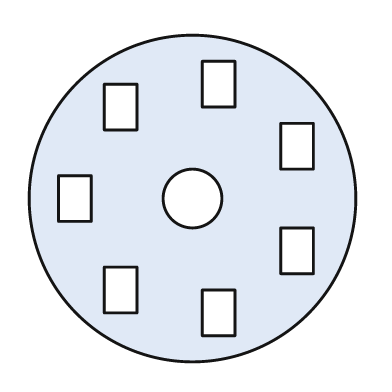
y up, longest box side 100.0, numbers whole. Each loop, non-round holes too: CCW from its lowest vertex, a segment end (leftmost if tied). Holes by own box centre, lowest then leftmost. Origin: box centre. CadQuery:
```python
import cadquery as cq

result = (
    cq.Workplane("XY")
    .moveTo(0.0, 0.0)
    .circle(50.0)
    .moveTo(3.0, -42.0)
    .lineTo(13.0, -42.0)
    .lineTo(13.0, -28.0)
    .lineTo(3.0, -28.0)
    .close()
    .moveTo(-27.0, -35.0)
    .lineTo(-17.0, -35.0)
    .lineTo(-17.0, -21.0)
    .lineTo(-27.0, -21.0)
    .close()
    .moveTo(27.0, -23.0)
    .lineTo(37.0, -23.0)
    .lineTo(37.0, -9.0)
    .lineTo(27.0, -9.0)
    .close()
    .moveTo(-41.0, -7.0)
    .lineTo(-31.0, -7.0)
    .lineTo(-31.0, 7.0)
    .lineTo(-41.0, 7.0)
    .close()
    .moveTo(0.0, 0.0)
    .circle(9.0)
    .moveTo(27.0, 9.0)
    .lineTo(37.0, 9.0)
    .lineTo(37.0, 23.0)
    .lineTo(27.0, 23.0)
    .close()
    .moveTo(-27.0, 21.0)
    .lineTo(-17.0, 21.0)
    .lineTo(-17.0, 35.0)
    .lineTo(-27.0, 35.0)
    .close()
    .moveTo(3.0, 28.0)
    .lineTo(13.0, 28.0)
    .lineTo(13.0, 42.0)
    .lineTo(3.0, 42.0)
    .close()
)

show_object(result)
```